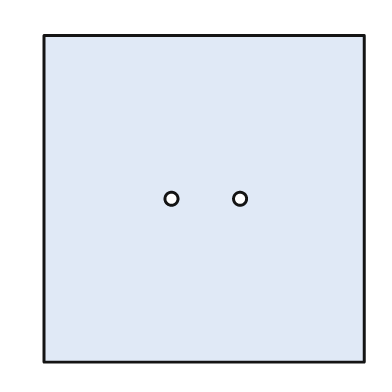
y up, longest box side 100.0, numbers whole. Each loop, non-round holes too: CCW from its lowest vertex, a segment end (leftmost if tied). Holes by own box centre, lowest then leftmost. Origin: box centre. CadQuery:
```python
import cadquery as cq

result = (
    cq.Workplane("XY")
    .moveTo(-49.0, -50.0)
    .lineTo(49.0, -50.0)
    .lineTo(49.0, 50.0)
    .lineTo(-49.0, 50.0)
    .close()
    .moveTo(-10.0, 0.0)
    .circle(2.0)
    .moveTo(11.0, 0.0)
    .circle(2.0)
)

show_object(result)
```